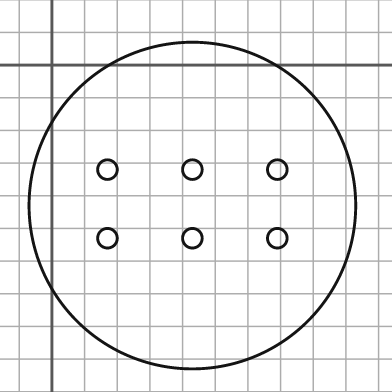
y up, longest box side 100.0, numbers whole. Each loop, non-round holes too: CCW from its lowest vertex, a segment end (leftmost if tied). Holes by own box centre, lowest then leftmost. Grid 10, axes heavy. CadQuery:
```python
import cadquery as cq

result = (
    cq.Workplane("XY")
    .moveTo(43.0, -43.0)
    .circle(50.0)
    .moveTo(17.0, -53.0)
    .circle(3.0)
    .moveTo(43.0, -53.0)
    .circle(3.0)
    .moveTo(69.0, -53.0)
    .circle(3.0)
    .moveTo(17.0, -32.0)
    .circle(3.0)
    .moveTo(43.0, -32.0)
    .circle(3.0)
    .moveTo(69.0, -32.0)
    .circle(3.0)
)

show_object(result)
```